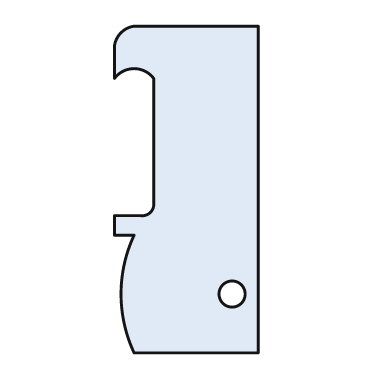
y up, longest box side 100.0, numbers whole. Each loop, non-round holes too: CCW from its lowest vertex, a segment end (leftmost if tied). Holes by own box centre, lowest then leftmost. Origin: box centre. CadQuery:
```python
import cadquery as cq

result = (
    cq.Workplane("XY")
    .moveTo(-16.0, -50.0)
    .lineTo(22.0, -50.0)
    .lineTo(22.0, 50.0)
    .lineTo(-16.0, 50.0)
    .threePointArc((-20.0, 48.0), (-22.0, 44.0))
    .lineTo(-22.0, 34.0)
    .threePointArc((-16.0, 37.0), (-10.0, 34.0))
    .lineTo(-10.0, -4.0)
    .threePointArc((-11.0, -7.0), (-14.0, -8.0))
    .lineTo(-22.0, -8.0)
    .lineTo(-22.0, -14.0)
    .lineTo(-16.0, -14.0)
    .threePointArc((-20.0, -32.0), (-16.0, -50.0))
    .close()
    .moveTo(14.0, -32.0)
    .circle(4.0)
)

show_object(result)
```